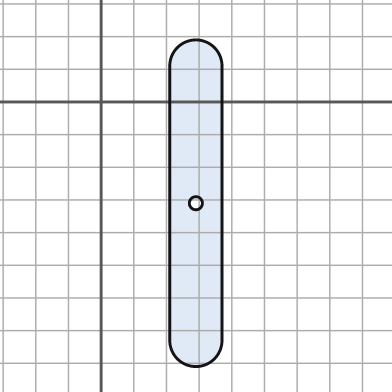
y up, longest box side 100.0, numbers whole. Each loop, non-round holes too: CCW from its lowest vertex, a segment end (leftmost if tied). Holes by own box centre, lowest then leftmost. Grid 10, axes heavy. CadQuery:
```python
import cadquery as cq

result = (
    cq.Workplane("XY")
    .moveTo(21.0, -73.0)
    .threePointArc((29.0, -81.0), (37.0, -73.0))
    .lineTo(37.0, 11.0)
    .threePointArc((29.0, 19.0), (21.0, 11.0))
    .close()
    .moveTo(29.0, -31.0)
    .circle(2.0)
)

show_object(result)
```